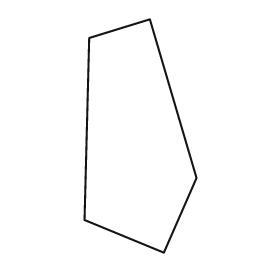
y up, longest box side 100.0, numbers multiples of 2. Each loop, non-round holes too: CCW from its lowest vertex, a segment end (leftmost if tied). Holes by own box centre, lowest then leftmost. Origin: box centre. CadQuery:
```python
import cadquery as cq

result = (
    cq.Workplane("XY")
    .moveTo(10.0, -50.0)
    .lineTo(24.0, -18.0)
    .lineTo(4.0, 50.0)
    .lineTo(-22.0, 42.0)
    .lineTo(-24.0, -36.0)
    .close()
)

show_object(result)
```